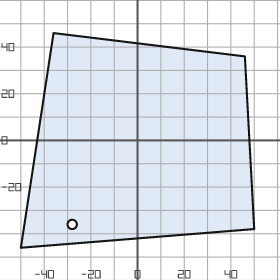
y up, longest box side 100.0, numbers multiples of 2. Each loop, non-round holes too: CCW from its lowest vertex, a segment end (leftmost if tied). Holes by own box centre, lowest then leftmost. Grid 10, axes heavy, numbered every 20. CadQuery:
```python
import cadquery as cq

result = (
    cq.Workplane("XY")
    .moveTo(-50.0, -46.0)
    .lineTo(50.0, -38.0)
    .lineTo(46.0, 36.0)
    .lineTo(-36.0, 46.0)
    .close()
    .moveTo(-28.0, -36.0)
    .circle(2.0)
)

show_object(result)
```